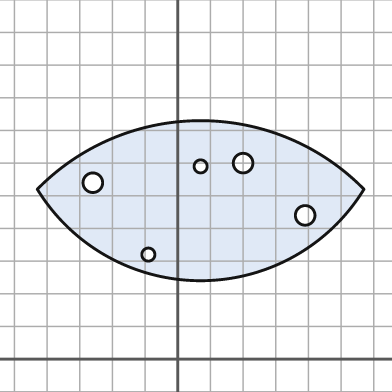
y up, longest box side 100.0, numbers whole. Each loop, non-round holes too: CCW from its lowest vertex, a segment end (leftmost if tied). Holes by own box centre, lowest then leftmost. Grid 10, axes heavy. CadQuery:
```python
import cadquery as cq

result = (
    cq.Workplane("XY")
    .moveTo(-43.0, 52.0)
    .threePointArc((7.0, 24.0), (57.0, 52.0))
    .threePointArc((7.0, 73.0), (-43.0, 52.0))
    .close()
    .moveTo(-9.0, 32.0)
    .circle(2.0)
    .moveTo(39.0, 44.0)
    .circle(3.0)
    .moveTo(-26.0, 54.0)
    .circle(3.0)
    .moveTo(7.0, 59.0)
    .circle(2.0)
    .moveTo(20.0, 60.0)
    .circle(3.0)
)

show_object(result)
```